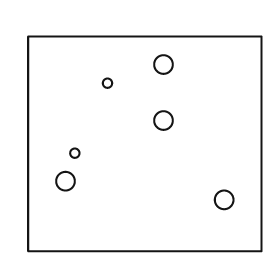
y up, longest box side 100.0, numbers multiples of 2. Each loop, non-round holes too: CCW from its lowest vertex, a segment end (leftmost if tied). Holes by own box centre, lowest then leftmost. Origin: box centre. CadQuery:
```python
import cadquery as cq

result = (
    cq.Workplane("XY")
    .moveTo(-50.0, -46.0)
    .lineTo(50.0, -46.0)
    .lineTo(50.0, 46.0)
    .lineTo(-50.0, 46.0)
    .close()
    .moveTo(34.0, -24.0)
    .circle(4.0)
    .moveTo(-34.0, -16.0)
    .circle(4.0)
    .moveTo(-30.0, -4.0)
    .circle(2.0)
    .moveTo(8.0, 10.0)
    .circle(4.0)
    .moveTo(-16.0, 26.0)
    .circle(2.0)
    .moveTo(8.0, 34.0)
    .circle(4.0)
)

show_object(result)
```